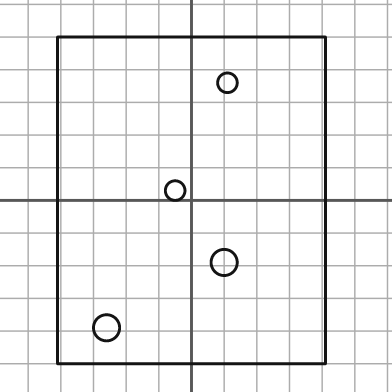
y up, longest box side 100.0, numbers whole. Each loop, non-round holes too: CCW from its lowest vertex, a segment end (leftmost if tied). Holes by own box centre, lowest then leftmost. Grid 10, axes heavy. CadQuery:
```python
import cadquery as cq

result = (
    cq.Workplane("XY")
    .moveTo(-41.0, -50.0)
    .lineTo(41.0, -50.0)
    .lineTo(41.0, 50.0)
    .lineTo(-41.0, 50.0)
    .close()
    .moveTo(-26.0, -39.0)
    .circle(4.0)
    .moveTo(10.0, -19.0)
    .circle(4.0)
    .moveTo(-5.0, 3.0)
    .circle(3.0)
    .moveTo(11.0, 36.0)
    .circle(3.0)
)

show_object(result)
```